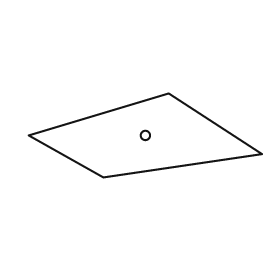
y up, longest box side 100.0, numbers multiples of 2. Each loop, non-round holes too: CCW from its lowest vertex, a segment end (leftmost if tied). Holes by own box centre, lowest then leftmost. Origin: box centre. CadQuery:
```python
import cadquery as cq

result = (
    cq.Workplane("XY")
    .moveTo(-18.0, -18.0)
    .lineTo(50.0, -8.0)
    .lineTo(10.0, 18.0)
    .lineTo(-50.0, 0.0)
    .close()
    .moveTo(0.0, 0.0)
    .circle(2.0)
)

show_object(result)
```